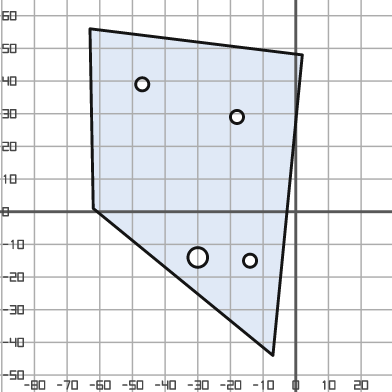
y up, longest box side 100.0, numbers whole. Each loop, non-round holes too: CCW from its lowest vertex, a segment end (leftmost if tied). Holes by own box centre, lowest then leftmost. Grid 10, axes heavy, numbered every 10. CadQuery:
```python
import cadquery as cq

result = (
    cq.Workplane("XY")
    .moveTo(-7.0, -44.0)
    .lineTo(2.0, 48.0)
    .lineTo(-63.0, 56.0)
    .lineTo(-62.0, 1.0)
    .close()
    .moveTo(-14.0, -15.0)
    .circle(2.0)
    .moveTo(-30.0, -14.0)
    .circle(3.0)
    .moveTo(-18.0, 29.0)
    .circle(2.0)
    .moveTo(-47.0, 39.0)
    .circle(2.0)
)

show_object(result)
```